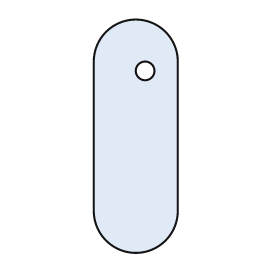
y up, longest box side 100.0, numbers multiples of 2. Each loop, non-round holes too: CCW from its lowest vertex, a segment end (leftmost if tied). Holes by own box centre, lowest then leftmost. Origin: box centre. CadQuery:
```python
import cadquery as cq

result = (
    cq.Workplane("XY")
    .moveTo(-18.0, -32.0)
    .threePointArc((0.0, -50.0), (18.0, -32.0))
    .lineTo(18.0, 32.0)
    .threePointArc((0.0, 50.0), (-18.0, 32.0))
    .close()
    .moveTo(4.0, 28.0)
    .circle(4.0)
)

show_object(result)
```